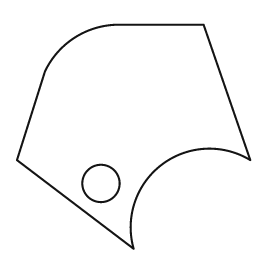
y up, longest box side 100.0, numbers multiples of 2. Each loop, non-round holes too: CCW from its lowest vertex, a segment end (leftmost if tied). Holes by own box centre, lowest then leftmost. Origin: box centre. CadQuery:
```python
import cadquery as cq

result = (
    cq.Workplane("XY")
    .moveTo(0.0, -48.0)
    .threePointArc((12.0, -12.0), (50.0, -10.0))
    .lineTo(30.0, 48.0)
    .lineTo(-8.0, 48.0)
    .threePointArc((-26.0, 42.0), (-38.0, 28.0))
    .lineTo(-50.0, -10.0)
    .close()
    .moveTo(-14.0, -20.0)
    .circle(8.0)
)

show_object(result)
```